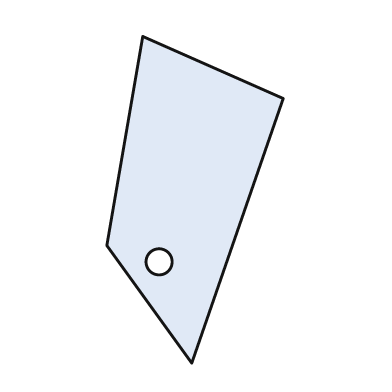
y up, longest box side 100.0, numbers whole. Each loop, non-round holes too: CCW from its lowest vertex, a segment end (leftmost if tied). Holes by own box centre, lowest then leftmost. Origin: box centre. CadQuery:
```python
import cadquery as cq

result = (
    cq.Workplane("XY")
    .moveTo(-1.0, -50.0)
    .lineTo(27.0, 31.0)
    .lineTo(-16.0, 50.0)
    .lineTo(-27.0, -14.0)
    .close()
    .moveTo(-11.0, -19.0)
    .circle(4.0)
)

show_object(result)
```